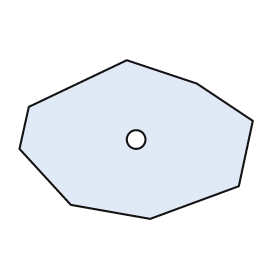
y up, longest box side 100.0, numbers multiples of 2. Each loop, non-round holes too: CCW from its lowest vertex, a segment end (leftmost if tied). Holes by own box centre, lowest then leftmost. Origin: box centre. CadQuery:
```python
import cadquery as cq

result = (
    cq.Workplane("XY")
    .moveTo(6.0, -34.0)
    .lineTo(44.0, -20.0)
    .lineTo(50.0, 8.0)
    .lineTo(26.0, 24.0)
    .lineTo(-4.0, 34.0)
    .lineTo(-46.0, 14.0)
    .lineTo(-50.0, -4.0)
    .lineTo(-28.0, -28.0)
    .close()
    .moveTo(0.0, 0.0)
    .circle(4.0)
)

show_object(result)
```